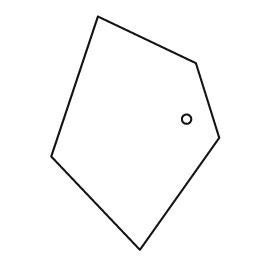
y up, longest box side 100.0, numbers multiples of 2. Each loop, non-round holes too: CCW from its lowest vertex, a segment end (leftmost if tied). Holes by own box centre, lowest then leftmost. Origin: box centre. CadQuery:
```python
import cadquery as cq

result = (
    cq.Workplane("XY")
    .moveTo(2.0, -50.0)
    .lineTo(36.0, -2.0)
    .lineTo(26.0, 30.0)
    .lineTo(-16.0, 50.0)
    .lineTo(-36.0, -10.0)
    .close()
    .moveTo(22.0, 6.0)
    .circle(2.0)
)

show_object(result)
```